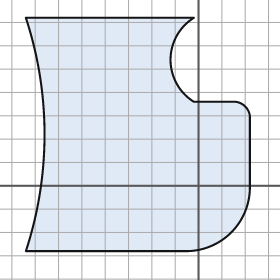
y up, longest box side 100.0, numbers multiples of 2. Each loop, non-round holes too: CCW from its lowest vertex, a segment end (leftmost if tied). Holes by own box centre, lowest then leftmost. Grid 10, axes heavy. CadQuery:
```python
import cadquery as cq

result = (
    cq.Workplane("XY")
    .moveTo(-74.0, -28.0)
    .lineTo(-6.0, -28.0)
    .threePointArc((14.0, -20.0), (22.0, 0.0))
    .lineTo(22.0, 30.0)
    .threePointArc((20.0, 34.0), (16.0, 36.0))
    .lineTo(-2.0, 36.0)
    .threePointArc((-12.0, 54.0), (-2.0, 72.0))
    .lineTo(-74.0, 72.0)
    .threePointArc((-66.0, 22.0), (-74.0, -28.0))
    .close()
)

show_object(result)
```